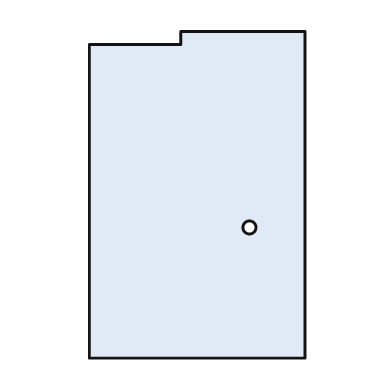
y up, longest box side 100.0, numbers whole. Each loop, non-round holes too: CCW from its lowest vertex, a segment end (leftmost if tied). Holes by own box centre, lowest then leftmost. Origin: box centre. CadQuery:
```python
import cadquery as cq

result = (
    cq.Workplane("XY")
    .moveTo(-33.0, -50.0)
    .lineTo(33.0, -50.0)
    .lineTo(33.0, 50.0)
    .lineTo(-5.0, 50.0)
    .lineTo(-5.0, 46.0)
    .lineTo(-33.0, 46.0)
    .close()
    .moveTo(16.0, -10.0)
    .circle(2.0)
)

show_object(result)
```